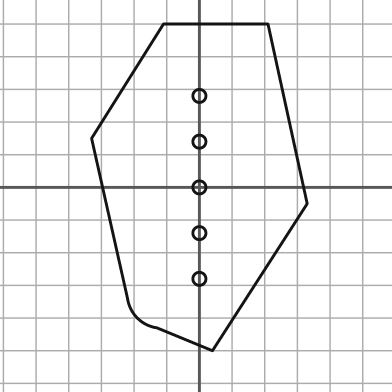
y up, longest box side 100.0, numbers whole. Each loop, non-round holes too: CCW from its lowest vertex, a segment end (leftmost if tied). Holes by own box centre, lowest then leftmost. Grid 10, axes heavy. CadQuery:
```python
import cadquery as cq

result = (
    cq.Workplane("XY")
    .moveTo(4.0, -50.0)
    .lineTo(33.0, -5.0)
    .lineTo(21.0, 50.0)
    .lineTo(-11.0, 50.0)
    .lineTo(-33.0, 15.0)
    .lineTo(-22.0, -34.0)
    .threePointArc((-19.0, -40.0), (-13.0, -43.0))
    .close()
    .moveTo(0.0, -28.0)
    .circle(2.0)
    .moveTo(0.0, -14.0)
    .circle(2.0)
    .moveTo(0.0, 0.0)
    .circle(2.0)
    .moveTo(0.0, 14.0)
    .circle(2.0)
    .moveTo(0.0, 28.0)
    .circle(2.0)
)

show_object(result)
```